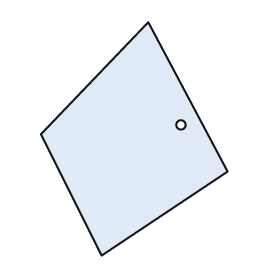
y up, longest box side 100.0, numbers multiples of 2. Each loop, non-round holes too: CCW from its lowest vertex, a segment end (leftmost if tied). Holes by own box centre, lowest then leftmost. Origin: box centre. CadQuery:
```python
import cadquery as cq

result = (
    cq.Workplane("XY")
    .moveTo(-14.0, -50.0)
    .lineTo(40.0, -14.0)
    .lineTo(6.0, 50.0)
    .lineTo(-40.0, 2.0)
    .close()
    .moveTo(20.0, 6.0)
    .circle(2.0)
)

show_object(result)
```